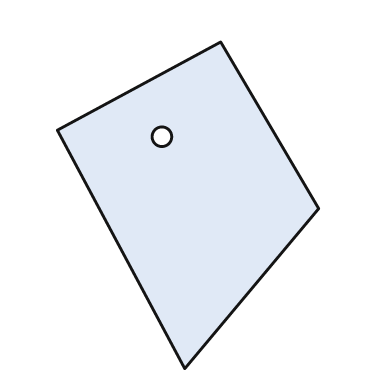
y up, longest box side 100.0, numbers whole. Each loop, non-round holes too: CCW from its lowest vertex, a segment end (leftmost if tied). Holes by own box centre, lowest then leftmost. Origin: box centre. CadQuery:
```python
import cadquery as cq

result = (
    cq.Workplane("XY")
    .moveTo(-1.0, -50.0)
    .lineTo(40.0, -1.0)
    .lineTo(10.0, 50.0)
    .lineTo(-40.0, 23.0)
    .close()
    .moveTo(-8.0, 21.0)
    .circle(3.0)
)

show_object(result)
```